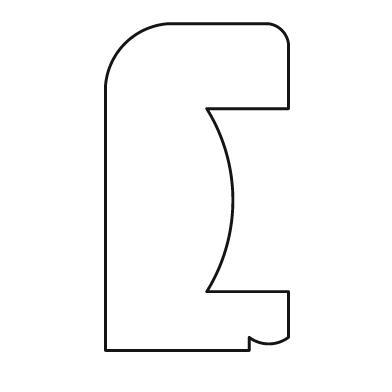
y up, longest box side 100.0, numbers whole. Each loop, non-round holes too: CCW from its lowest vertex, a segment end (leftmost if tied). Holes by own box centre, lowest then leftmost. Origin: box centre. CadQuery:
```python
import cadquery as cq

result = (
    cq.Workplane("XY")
    .moveTo(-28.0, -50.0)
    .lineTo(16.0, -50.0)
    .lineTo(16.0, -46.0)
    .threePointArc((22.0, -48.0), (28.0, -46.0))
    .lineTo(28.0, -32.0)
    .lineTo(3.0, -32.0)
    .threePointArc((11.0, -4.0), (3.0, 24.0))
    .lineTo(28.0, 24.0)
    .lineTo(28.0, 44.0)
    .threePointArc((26.0, 48.0), (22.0, 50.0))
    .lineTo(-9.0, 50.0)
    .threePointArc((-22.0, 44.0), (-28.0, 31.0))
    .close()
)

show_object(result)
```